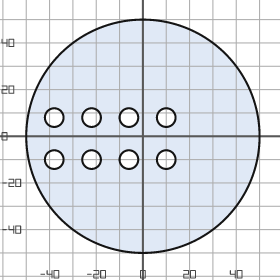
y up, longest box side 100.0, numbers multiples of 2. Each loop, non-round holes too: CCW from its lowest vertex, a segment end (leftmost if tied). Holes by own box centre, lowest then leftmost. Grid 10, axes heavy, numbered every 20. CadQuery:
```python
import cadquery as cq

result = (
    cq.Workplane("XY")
    .moveTo(0.0, 0.0)
    .circle(50.0)
    .moveTo(-38.0, -10.0)
    .circle(4.0)
    .moveTo(-22.0, -10.0)
    .circle(4.0)
    .moveTo(-6.0, -10.0)
    .circle(4.0)
    .moveTo(10.0, -10.0)
    .circle(4.0)
    .moveTo(-38.0, 8.0)
    .circle(4.0)
    .moveTo(-22.0, 8.0)
    .circle(4.0)
    .moveTo(-6.0, 8.0)
    .circle(4.0)
    .moveTo(10.0, 8.0)
    .circle(4.0)
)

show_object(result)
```